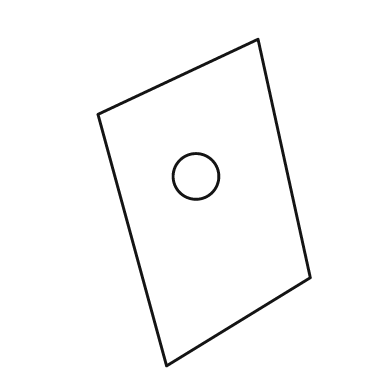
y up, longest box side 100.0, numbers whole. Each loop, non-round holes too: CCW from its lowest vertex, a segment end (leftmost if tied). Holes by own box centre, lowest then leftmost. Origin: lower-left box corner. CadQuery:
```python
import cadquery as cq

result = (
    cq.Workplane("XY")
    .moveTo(21.0, 0.0)
    .lineTo(65.0, 27.0)
    .lineTo(49.0, 100.0)
    .lineTo(0.0, 77.0)
    .close()
    .moveTo(30.0, 58.0)
    .circle(7.0)
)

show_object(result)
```